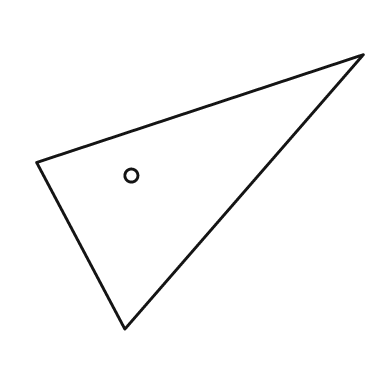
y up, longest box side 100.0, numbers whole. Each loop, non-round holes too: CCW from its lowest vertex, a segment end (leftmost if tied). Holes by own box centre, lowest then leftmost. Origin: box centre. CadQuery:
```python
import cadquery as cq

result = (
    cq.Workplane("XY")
    .moveTo(-23.0, -42.0)
    .lineTo(50.0, 42.0)
    .lineTo(-50.0, 9.0)
    .close()
    .moveTo(-21.0, 5.0)
    .circle(2.0)
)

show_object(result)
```